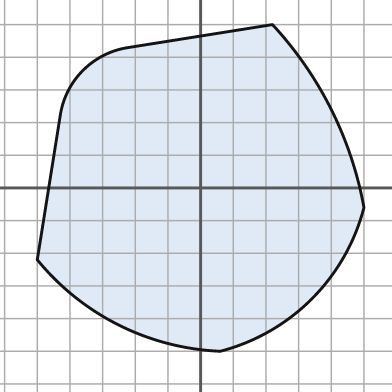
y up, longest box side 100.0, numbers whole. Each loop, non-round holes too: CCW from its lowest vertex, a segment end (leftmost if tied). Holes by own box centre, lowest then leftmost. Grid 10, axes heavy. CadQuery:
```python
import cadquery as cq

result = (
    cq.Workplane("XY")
    .moveTo(6.0, -50.0)
    .threePointArc((34.0, -34.0), (50.0, -6.0))
    .threePointArc((40.0, 24.0), (22.0, 50.0))
    .lineTo(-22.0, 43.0)
    .threePointArc((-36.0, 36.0), (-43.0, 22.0))
    .lineTo(-50.0, -22.0)
    .threePointArc((-25.0, -42.0), (6.0, -50.0))
    .close()
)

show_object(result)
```